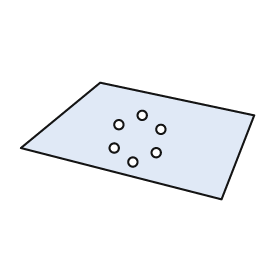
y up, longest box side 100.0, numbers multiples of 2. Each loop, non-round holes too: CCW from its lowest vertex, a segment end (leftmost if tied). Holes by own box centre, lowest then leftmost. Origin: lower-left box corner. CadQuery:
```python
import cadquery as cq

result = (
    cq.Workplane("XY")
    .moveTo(86.0, 0.0)
    .lineTo(100.0, 36.0)
    .lineTo(34.0, 50.0)
    .lineTo(0.0, 22.0)
    .close()
    .moveTo(48.0, 16.0)
    .circle(2.0)
    .moveTo(58.0, 20.0)
    .circle(2.0)
    .moveTo(40.0, 22.0)
    .circle(2.0)
    .moveTo(60.0, 30.0)
    .circle(2.0)
    .moveTo(42.0, 32.0)
    .circle(2.0)
    .moveTo(52.0, 36.0)
    .circle(2.0)
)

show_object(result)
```